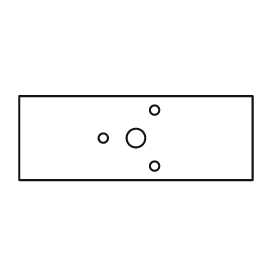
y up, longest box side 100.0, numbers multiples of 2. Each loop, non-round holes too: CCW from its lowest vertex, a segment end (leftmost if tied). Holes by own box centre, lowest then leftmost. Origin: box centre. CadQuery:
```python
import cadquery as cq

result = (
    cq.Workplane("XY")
    .moveTo(-50.0, -18.0)
    .lineTo(50.0, -18.0)
    .lineTo(50.0, 18.0)
    .lineTo(-50.0, 18.0)
    .close()
    .moveTo(8.0, -12.0)
    .circle(2.0)
    .moveTo(-14.0, 0.0)
    .circle(2.0)
    .moveTo(0.0, 0.0)
    .circle(4.0)
    .moveTo(8.0, 12.0)
    .circle(2.0)
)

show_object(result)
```